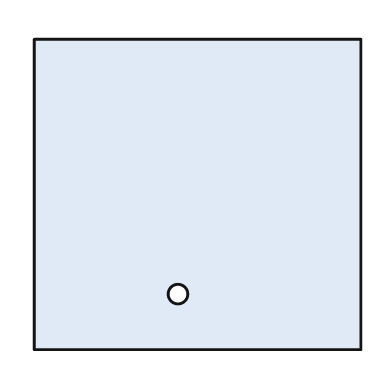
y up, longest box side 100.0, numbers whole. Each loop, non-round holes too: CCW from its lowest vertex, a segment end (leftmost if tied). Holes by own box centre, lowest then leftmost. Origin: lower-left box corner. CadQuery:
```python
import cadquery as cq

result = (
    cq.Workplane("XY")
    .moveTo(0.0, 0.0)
    .lineTo(100.0, 0.0)
    .lineTo(100.0, 95.0)
    .lineTo(0.0, 95.0)
    .close()
    .moveTo(44.0, 17.0)
    .circle(3.0)
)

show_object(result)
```